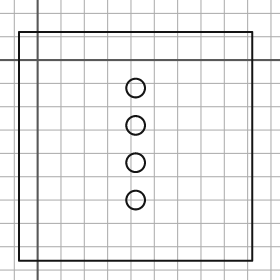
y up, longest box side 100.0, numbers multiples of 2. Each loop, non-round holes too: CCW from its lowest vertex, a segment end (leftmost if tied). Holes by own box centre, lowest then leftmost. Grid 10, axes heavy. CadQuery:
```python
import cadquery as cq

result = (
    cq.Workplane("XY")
    .moveTo(-8.0, -86.0)
    .lineTo(92.0, -86.0)
    .lineTo(92.0, 12.0)
    .lineTo(-8.0, 12.0)
    .close()
    .moveTo(42.0, -60.0)
    .circle(4.0)
    .moveTo(42.0, -44.0)
    .circle(4.0)
    .moveTo(42.0, -28.0)
    .circle(4.0)
    .moveTo(42.0, -12.0)
    .circle(4.0)
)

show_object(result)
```